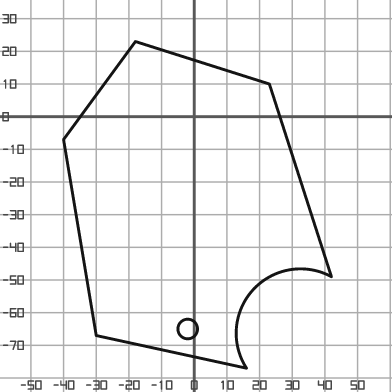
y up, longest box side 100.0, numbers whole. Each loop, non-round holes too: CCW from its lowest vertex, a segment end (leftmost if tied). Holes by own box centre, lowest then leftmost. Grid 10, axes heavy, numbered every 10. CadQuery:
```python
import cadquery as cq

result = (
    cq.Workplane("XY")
    .moveTo(16.0, -77.0)
    .threePointArc((18.0, -53.0), (42.0, -49.0))
    .lineTo(23.0, 10.0)
    .lineTo(-18.0, 23.0)
    .lineTo(-40.0, -7.0)
    .lineTo(-30.0, -67.0)
    .close()
    .moveTo(-2.0, -65.0)
    .circle(3.0)
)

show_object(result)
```